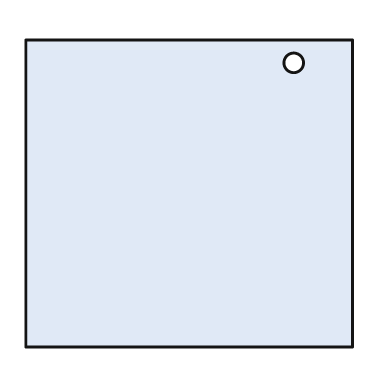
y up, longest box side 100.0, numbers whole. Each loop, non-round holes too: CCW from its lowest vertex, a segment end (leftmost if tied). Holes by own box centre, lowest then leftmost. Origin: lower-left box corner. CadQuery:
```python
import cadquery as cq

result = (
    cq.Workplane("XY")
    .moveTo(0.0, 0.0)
    .lineTo(100.0, 0.0)
    .lineTo(100.0, 94.0)
    .lineTo(0.0, 94.0)
    .close()
    .moveTo(82.0, 87.0)
    .circle(3.0)
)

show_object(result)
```